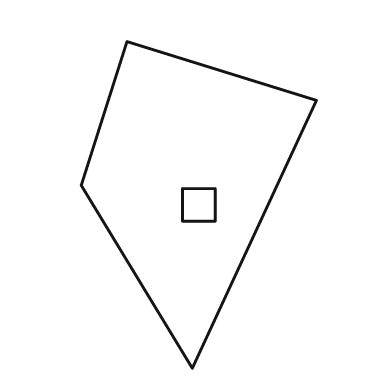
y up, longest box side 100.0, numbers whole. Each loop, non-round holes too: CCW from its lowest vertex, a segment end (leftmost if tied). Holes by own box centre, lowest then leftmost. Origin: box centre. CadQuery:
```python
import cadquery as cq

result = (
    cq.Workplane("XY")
    .moveTo(-2.0, -50.0)
    .lineTo(36.0, 32.0)
    .lineTo(-22.0, 50.0)
    .lineTo(-36.0, 6.0)
    .close()
    .moveTo(-5.0, -5.0)
    .lineTo(5.0, -5.0)
    .lineTo(5.0, 5.0)
    .lineTo(-5.0, 5.0)
    .close()
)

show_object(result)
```